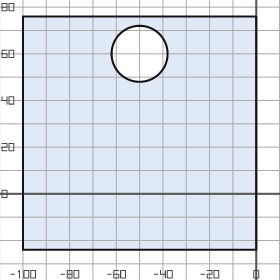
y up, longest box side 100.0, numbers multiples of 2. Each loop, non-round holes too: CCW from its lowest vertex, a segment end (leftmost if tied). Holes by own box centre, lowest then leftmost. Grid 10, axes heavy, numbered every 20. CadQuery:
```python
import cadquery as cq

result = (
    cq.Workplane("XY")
    .moveTo(-100.0, -24.0)
    .lineTo(0.0, -24.0)
    .lineTo(0.0, 76.0)
    .lineTo(-100.0, 76.0)
    .close()
    .moveTo(-50.0, 60.0)
    .circle(12.0)
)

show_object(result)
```